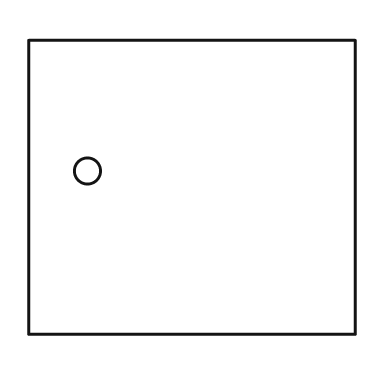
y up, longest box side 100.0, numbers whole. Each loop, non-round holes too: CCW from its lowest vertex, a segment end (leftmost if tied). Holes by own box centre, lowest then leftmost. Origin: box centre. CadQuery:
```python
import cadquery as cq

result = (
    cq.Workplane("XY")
    .moveTo(-50.0, -45.0)
    .lineTo(50.0, -45.0)
    .lineTo(50.0, 45.0)
    .lineTo(-50.0, 45.0)
    .close()
    .moveTo(-32.0, 5.0)
    .circle(4.0)
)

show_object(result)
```